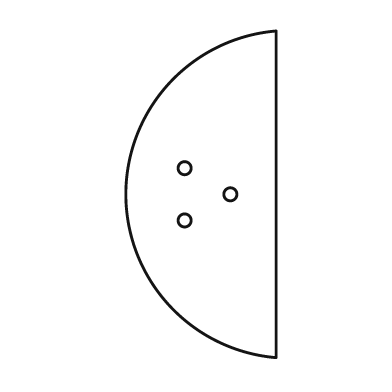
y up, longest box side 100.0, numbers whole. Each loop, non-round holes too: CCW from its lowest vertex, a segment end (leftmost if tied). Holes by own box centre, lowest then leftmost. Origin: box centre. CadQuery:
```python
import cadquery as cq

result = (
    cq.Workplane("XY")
    .moveTo(23.0, -50.0)
    .lineTo(23.0, 50.0)
    .threePointArc((-23.0, 0.0), (23.0, -50.0))
    .close()
    .moveTo(-5.0, -8.0)
    .circle(2.0)
    .moveTo(9.0, 0.0)
    .circle(2.0)
    .moveTo(-5.0, 8.0)
    .circle(2.0)
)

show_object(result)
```